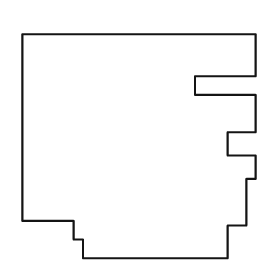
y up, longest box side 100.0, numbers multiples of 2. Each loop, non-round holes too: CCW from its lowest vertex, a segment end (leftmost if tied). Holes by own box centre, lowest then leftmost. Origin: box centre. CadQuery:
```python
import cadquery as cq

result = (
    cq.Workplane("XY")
    .moveTo(-24.0, -48.0)
    .lineTo(38.0, -48.0)
    .lineTo(38.0, -34.0)
    .lineTo(46.0, -34.0)
    .lineTo(46.0, -14.0)
    .lineTo(50.0, -14.0)
    .lineTo(50.0, -4.0)
    .lineTo(38.0, -4.0)
    .lineTo(38.0, 6.0)
    .lineTo(50.0, 6.0)
    .lineTo(50.0, 22.0)
    .lineTo(24.0, 22.0)
    .lineTo(24.0, 30.0)
    .lineTo(50.0, 30.0)
    .lineTo(50.0, 48.0)
    .lineTo(-50.0, 48.0)
    .lineTo(-50.0, -32.0)
    .lineTo(-28.0, -32.0)
    .lineTo(-28.0, -40.0)
    .lineTo(-24.0, -40.0)
    .close()
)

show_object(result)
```